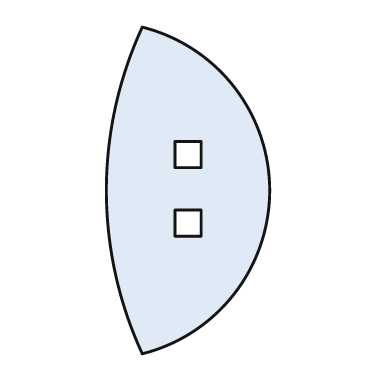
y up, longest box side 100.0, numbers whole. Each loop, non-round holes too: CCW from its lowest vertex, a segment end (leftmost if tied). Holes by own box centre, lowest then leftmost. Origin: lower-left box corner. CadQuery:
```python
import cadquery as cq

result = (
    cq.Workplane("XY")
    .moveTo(11.0, 0.0)
    .threePointArc((50.0, 50.0), (11.0, 100.0))
    .threePointArc((0.0, 50.0), (11.0, 0.0))
    .close()
    .moveTo(21.0, 36.0)
    .lineTo(29.0, 36.0)
    .lineTo(29.0, 44.0)
    .lineTo(21.0, 44.0)
    .close()
    .moveTo(21.0, 57.0)
    .lineTo(29.0, 57.0)
    .lineTo(29.0, 65.0)
    .lineTo(21.0, 65.0)
    .close()
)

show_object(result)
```